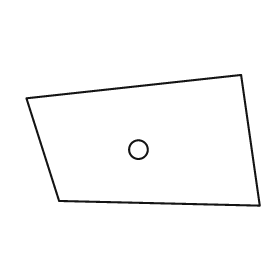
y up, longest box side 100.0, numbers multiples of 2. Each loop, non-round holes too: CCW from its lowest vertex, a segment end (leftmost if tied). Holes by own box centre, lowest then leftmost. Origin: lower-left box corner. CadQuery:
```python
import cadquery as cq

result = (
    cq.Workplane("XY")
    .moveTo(100.0, 0.0)
    .lineTo(92.0, 56.0)
    .lineTo(0.0, 46.0)
    .lineTo(14.0, 2.0)
    .close()
    .moveTo(48.0, 24.0)
    .circle(4.0)
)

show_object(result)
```